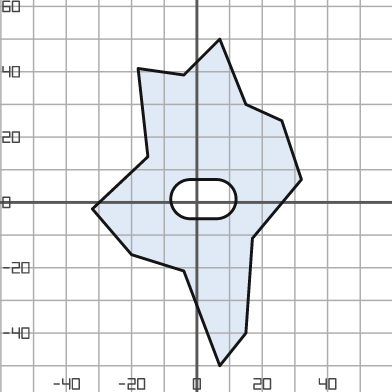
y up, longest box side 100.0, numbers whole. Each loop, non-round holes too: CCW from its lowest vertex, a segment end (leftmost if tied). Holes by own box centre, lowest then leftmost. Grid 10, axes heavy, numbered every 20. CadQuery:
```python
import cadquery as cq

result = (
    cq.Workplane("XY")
    .moveTo(7.0, -50.0)
    .lineTo(15.0, -40.0)
    .lineTo(17.0, -11.0)
    .lineTo(32.0, 7.0)
    .lineTo(26.0, 25.0)
    .lineTo(15.0, 30.0)
    .lineTo(7.0, 50.0)
    .lineTo(-4.0, 39.0)
    .lineTo(-18.0, 41.0)
    .lineTo(-15.0, 14.0)
    .lineTo(-32.0, -2.0)
    .lineTo(-20.0, -16.0)
    .lineTo(-4.0, -21.0)
    .close()
    .moveTo(-2.0, -5.0)
    .lineTo(6.0, -5.0)
    .threePointArc((12.0, 1.0), (6.0, 7.0))
    .lineTo(-2.0, 7.0)
    .threePointArc((-8.0, 1.0), (-2.0, -5.0))
    .close()
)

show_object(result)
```